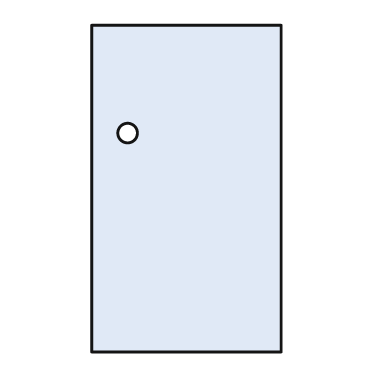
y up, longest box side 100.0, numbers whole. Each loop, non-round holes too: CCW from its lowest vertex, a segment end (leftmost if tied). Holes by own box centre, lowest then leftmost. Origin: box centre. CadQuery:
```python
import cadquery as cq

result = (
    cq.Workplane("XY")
    .moveTo(-29.0, -50.0)
    .lineTo(29.0, -50.0)
    .lineTo(29.0, 50.0)
    .lineTo(-29.0, 50.0)
    .close()
    .moveTo(-18.0, 17.0)
    .circle(3.0)
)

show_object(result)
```